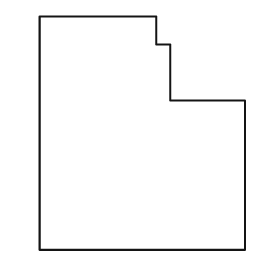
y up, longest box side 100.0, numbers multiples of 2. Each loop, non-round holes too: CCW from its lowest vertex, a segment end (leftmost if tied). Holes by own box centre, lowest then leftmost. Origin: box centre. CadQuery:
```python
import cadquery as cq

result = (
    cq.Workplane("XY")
    .moveTo(-44.0, -50.0)
    .lineTo(44.0, -50.0)
    .lineTo(44.0, 14.0)
    .lineTo(12.0, 14.0)
    .lineTo(12.0, 38.0)
    .lineTo(6.0, 38.0)
    .lineTo(6.0, 50.0)
    .lineTo(-44.0, 50.0)
    .close()
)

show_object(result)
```